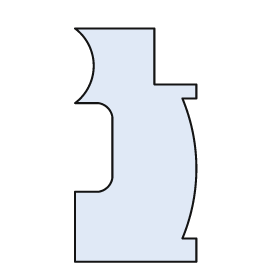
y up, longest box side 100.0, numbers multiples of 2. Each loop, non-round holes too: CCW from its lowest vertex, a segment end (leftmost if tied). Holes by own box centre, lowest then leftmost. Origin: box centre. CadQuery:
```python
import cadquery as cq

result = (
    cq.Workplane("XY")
    .moveTo(-26.0, -50.0)
    .lineTo(26.0, -50.0)
    .lineTo(26.0, -40.0)
    .lineTo(20.0, -40.0)
    .threePointArc((26.0, -10.0), (20.0, 20.0))
    .lineTo(26.0, 20.0)
    .lineTo(26.0, 26.0)
    .lineTo(8.0, 26.0)
    .lineTo(8.0, 50.0)
    .lineTo(-26.0, 50.0)
    .threePointArc((-18.0, 34.0), (-26.0, 18.0))
    .lineTo(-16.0, 18.0)
    .threePointArc((-12.0, 16.0), (-10.0, 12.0))
    .lineTo(-10.0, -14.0)
    .threePointArc((-12.0, -18.0), (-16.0, -20.0))
    .lineTo(-26.0, -20.0)
    .close()
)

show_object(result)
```